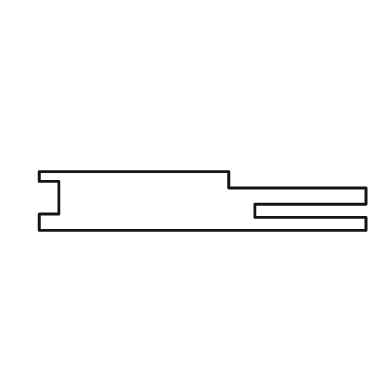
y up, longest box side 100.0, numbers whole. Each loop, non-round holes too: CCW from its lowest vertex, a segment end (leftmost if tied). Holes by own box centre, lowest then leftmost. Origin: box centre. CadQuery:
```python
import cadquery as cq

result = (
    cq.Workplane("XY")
    .moveTo(-50.0, -9.0)
    .lineTo(50.0, -9.0)
    .lineTo(50.0, -5.0)
    .lineTo(16.0, -5.0)
    .lineTo(16.0, -1.0)
    .lineTo(50.0, -1.0)
    .lineTo(50.0, 4.0)
    .lineTo(8.0, 4.0)
    .lineTo(8.0, 9.0)
    .lineTo(-50.0, 9.0)
    .lineTo(-50.0, 6.0)
    .lineTo(-44.0, 6.0)
    .lineTo(-44.0, -4.0)
    .lineTo(-50.0, -4.0)
    .close()
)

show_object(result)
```